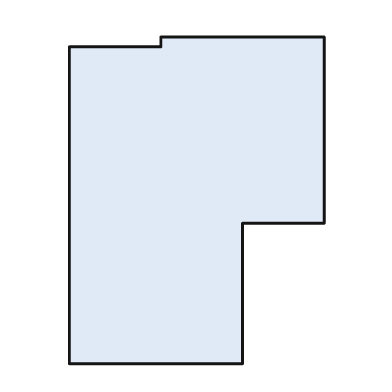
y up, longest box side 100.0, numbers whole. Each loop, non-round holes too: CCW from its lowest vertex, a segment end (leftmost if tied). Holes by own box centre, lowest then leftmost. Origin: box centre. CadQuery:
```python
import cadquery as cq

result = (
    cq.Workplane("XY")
    .moveTo(-39.0, -50.0)
    .lineTo(14.0, -50.0)
    .lineTo(14.0, -7.0)
    .lineTo(39.0, -7.0)
    .lineTo(39.0, 50.0)
    .lineTo(-11.0, 50.0)
    .lineTo(-11.0, 47.0)
    .lineTo(-39.0, 47.0)
    .close()
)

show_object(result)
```